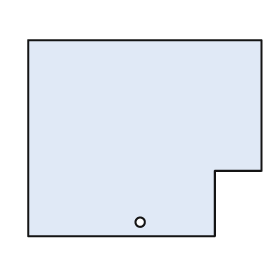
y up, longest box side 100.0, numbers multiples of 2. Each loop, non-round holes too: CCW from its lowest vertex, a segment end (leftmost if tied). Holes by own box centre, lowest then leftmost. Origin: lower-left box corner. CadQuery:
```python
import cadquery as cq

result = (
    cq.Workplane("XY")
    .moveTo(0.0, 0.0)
    .lineTo(80.0, 0.0)
    .lineTo(80.0, 28.0)
    .lineTo(100.0, 28.0)
    .lineTo(100.0, 84.0)
    .lineTo(0.0, 84.0)
    .close()
    .moveTo(48.0, 6.0)
    .circle(2.0)
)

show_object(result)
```